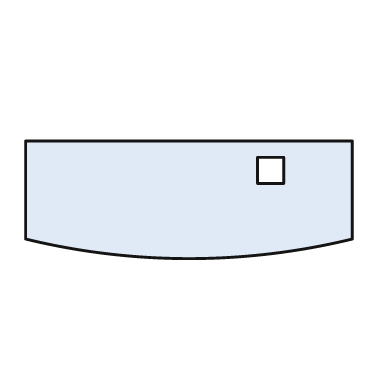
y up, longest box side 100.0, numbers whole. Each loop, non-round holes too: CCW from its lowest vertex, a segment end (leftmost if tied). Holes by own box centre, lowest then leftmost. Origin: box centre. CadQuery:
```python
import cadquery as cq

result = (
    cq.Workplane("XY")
    .moveTo(-50.0, -12.0)
    .threePointArc((0.0, -18.0), (50.0, -12.0))
    .lineTo(50.0, 18.0)
    .lineTo(-50.0, 18.0)
    .close()
    .moveTo(21.0, 5.0)
    .lineTo(29.0, 5.0)
    .lineTo(29.0, 13.0)
    .lineTo(21.0, 13.0)
    .close()
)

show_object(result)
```